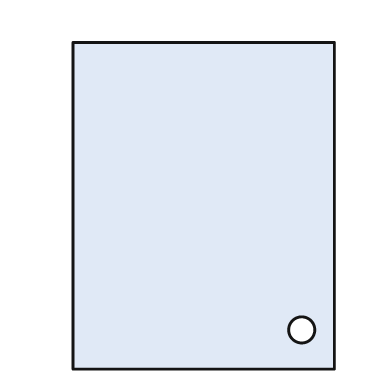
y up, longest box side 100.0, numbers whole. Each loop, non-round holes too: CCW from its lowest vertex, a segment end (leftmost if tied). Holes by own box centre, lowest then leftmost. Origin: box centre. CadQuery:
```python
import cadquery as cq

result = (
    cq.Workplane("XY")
    .moveTo(-40.0, -50.0)
    .lineTo(40.0, -50.0)
    .lineTo(40.0, 50.0)
    .lineTo(-40.0, 50.0)
    .close()
    .moveTo(30.0, -38.0)
    .circle(4.0)
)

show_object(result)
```